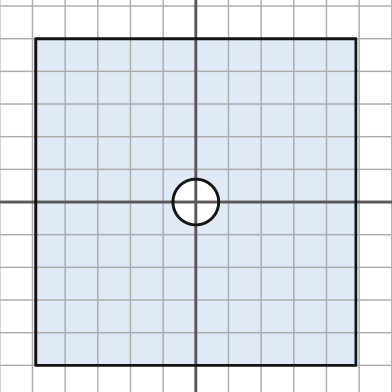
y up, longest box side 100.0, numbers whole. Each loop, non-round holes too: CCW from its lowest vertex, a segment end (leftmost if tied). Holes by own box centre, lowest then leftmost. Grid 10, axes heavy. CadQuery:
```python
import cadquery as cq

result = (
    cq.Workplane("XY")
    .moveTo(-49.0, -50.0)
    .lineTo(49.0, -50.0)
    .lineTo(49.0, 50.0)
    .lineTo(-49.0, 50.0)
    .close()
    .moveTo(0.0, 0.0)
    .circle(7.0)
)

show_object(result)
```